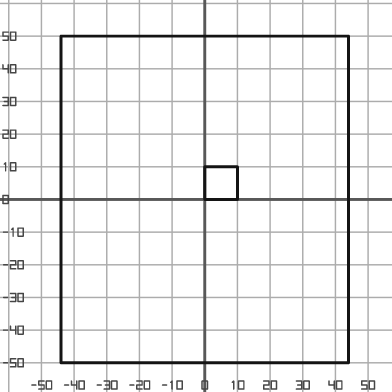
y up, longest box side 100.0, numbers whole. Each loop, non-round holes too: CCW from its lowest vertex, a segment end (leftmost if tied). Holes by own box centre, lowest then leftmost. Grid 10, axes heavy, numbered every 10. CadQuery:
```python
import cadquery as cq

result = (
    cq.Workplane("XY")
    .moveTo(-44.0, -50.0)
    .lineTo(44.0, -50.0)
    .lineTo(44.0, 50.0)
    .lineTo(-44.0, 50.0)
    .close()
    .moveTo(0.0, 0.0)
    .lineTo(10.0, 0.0)
    .lineTo(10.0, 10.0)
    .lineTo(0.0, 10.0)
    .close()
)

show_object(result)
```